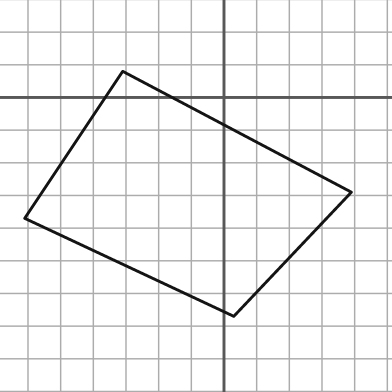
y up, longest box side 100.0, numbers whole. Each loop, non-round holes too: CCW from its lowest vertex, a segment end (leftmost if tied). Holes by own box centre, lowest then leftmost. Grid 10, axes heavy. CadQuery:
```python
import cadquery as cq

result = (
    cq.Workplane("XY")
    .moveTo(3.0, -67.0)
    .lineTo(39.0, -29.0)
    .lineTo(-31.0, 8.0)
    .lineTo(-61.0, -37.0)
    .close()
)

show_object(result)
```